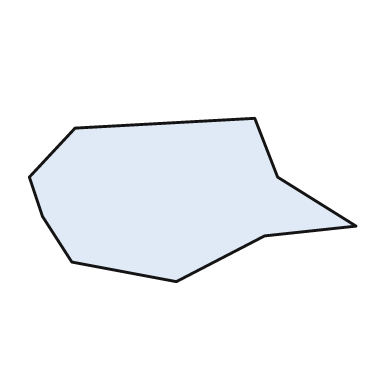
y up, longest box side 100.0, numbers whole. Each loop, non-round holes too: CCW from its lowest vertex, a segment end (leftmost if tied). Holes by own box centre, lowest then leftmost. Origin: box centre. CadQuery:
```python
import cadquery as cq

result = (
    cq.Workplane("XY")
    .moveTo(-5.0, -25.0)
    .lineTo(22.0, -11.0)
    .lineTo(50.0, -8.0)
    .lineTo(26.0, 7.0)
    .lineTo(19.0, 25.0)
    .lineTo(-36.0, 22.0)
    .lineTo(-50.0, 7.0)
    .lineTo(-46.0, -5.0)
    .lineTo(-37.0, -19.0)
    .close()
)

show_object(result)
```